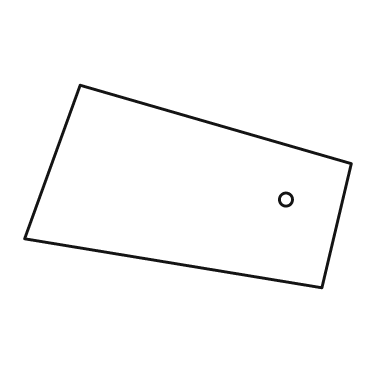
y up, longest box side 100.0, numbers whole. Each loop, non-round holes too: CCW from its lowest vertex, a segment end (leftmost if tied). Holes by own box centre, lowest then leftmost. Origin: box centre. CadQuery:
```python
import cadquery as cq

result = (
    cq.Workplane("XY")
    .moveTo(41.0, -31.0)
    .lineTo(50.0, 7.0)
    .lineTo(-33.0, 31.0)
    .lineTo(-50.0, -16.0)
    .close()
    .moveTo(30.0, -4.0)
    .circle(2.0)
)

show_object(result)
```